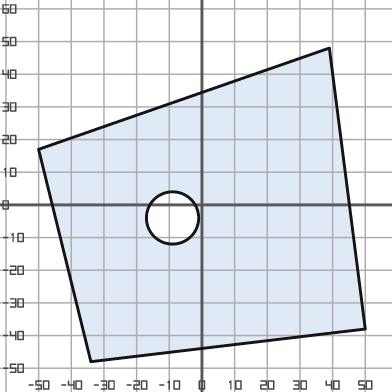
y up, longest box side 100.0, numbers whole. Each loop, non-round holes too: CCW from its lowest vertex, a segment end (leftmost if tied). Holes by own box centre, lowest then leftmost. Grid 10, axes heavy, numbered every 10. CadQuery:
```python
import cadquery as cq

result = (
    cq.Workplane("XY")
    .moveTo(-34.0, -48.0)
    .lineTo(50.0, -38.0)
    .lineTo(39.0, 48.0)
    .lineTo(-50.0, 17.0)
    .close()
    .moveTo(-9.0, -4.0)
    .circle(8.0)
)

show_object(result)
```